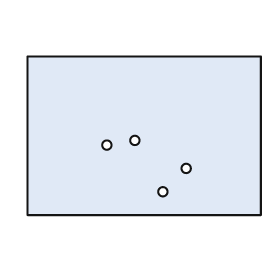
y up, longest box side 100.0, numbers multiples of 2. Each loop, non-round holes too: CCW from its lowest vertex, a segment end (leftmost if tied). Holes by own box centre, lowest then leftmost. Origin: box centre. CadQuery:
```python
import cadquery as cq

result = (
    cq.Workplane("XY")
    .moveTo(-50.0, -34.0)
    .lineTo(50.0, -34.0)
    .lineTo(50.0, 34.0)
    .lineTo(-50.0, 34.0)
    .close()
    .moveTo(8.0, -24.0)
    .circle(2.0)
    .moveTo(18.0, -14.0)
    .circle(2.0)
    .moveTo(-16.0, -4.0)
    .circle(2.0)
    .moveTo(-4.0, -2.0)
    .circle(2.0)
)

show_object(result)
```